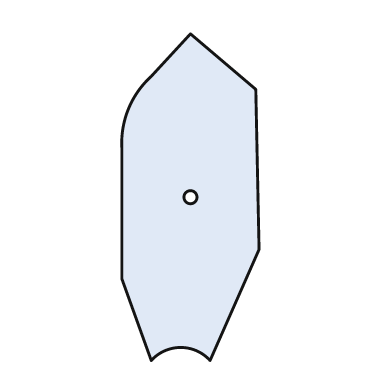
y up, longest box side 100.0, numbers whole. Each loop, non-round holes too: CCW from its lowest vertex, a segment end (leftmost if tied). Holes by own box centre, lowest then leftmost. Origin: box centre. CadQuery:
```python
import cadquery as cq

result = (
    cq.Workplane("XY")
    .moveTo(-12.0, -50.0)
    .threePointArc((-3.0, -46.0), (6.0, -50.0))
    .lineTo(21.0, -16.0)
    .lineTo(20.0, 33.0)
    .lineTo(0.0, 50.0)
    .lineTo(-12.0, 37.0)
    .threePointArc((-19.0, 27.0), (-21.0, 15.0))
    .lineTo(-21.0, -25.0)
    .close()
    .moveTo(0.0, 0.0)
    .circle(2.0)
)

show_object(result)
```